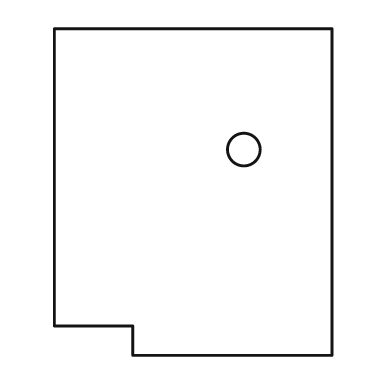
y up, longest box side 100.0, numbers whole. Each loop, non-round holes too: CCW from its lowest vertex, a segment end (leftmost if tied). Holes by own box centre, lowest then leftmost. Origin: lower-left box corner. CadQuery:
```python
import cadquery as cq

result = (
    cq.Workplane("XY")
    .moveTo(24.0, 0.0)
    .lineTo(85.0, 0.0)
    .lineTo(85.0, 100.0)
    .lineTo(0.0, 100.0)
    .lineTo(0.0, 9.0)
    .lineTo(24.0, 9.0)
    .close()
    .moveTo(58.0, 63.0)
    .circle(5.0)
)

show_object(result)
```